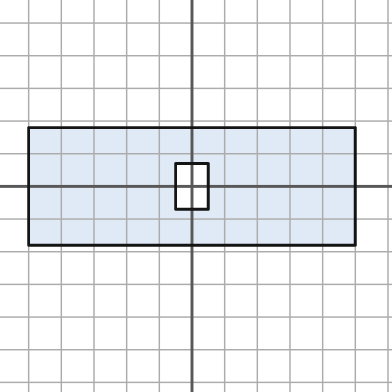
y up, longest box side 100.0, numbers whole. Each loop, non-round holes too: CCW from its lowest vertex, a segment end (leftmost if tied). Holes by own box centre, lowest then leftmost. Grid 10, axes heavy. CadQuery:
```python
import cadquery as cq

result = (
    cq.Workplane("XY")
    .moveTo(-50.0, -18.0)
    .lineTo(50.0, -18.0)
    .lineTo(50.0, 18.0)
    .lineTo(-50.0, 18.0)
    .close()
    .moveTo(-5.0, -7.0)
    .lineTo(5.0, -7.0)
    .lineTo(5.0, 7.0)
    .lineTo(-5.0, 7.0)
    .close()
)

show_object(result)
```